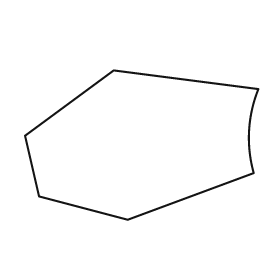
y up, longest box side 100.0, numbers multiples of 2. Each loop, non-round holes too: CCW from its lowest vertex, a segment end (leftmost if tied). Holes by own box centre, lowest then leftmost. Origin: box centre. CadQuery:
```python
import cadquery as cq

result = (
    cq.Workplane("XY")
    .moveTo(-6.0, -32.0)
    .lineTo(48.0, -12.0)
    .threePointArc((46.0, 6.0), (50.0, 24.0))
    .lineTo(-12.0, 32.0)
    .lineTo(-50.0, 4.0)
    .lineTo(-44.0, -22.0)
    .close()
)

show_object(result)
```